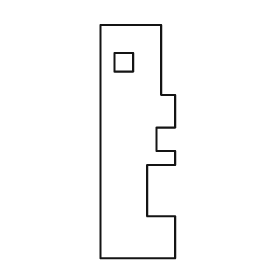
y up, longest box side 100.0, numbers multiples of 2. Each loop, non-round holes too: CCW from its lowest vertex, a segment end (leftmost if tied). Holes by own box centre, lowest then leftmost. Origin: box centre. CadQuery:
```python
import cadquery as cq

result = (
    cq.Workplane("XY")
    .moveTo(-16.0, -50.0)
    .lineTo(16.0, -50.0)
    .lineTo(16.0, -32.0)
    .lineTo(4.0, -32.0)
    .lineTo(4.0, -10.0)
    .lineTo(16.0, -10.0)
    .lineTo(16.0, -4.0)
    .lineTo(8.0, -4.0)
    .lineTo(8.0, 6.0)
    .lineTo(16.0, 6.0)
    .lineTo(16.0, 20.0)
    .lineTo(10.0, 20.0)
    .lineTo(10.0, 50.0)
    .lineTo(-16.0, 50.0)
    .close()
    .moveTo(-10.0, 30.0)
    .lineTo(-2.0, 30.0)
    .lineTo(-2.0, 38.0)
    .lineTo(-10.0, 38.0)
    .close()
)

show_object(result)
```